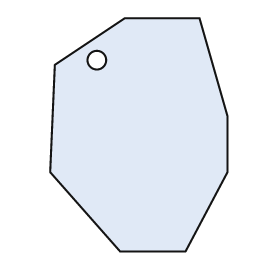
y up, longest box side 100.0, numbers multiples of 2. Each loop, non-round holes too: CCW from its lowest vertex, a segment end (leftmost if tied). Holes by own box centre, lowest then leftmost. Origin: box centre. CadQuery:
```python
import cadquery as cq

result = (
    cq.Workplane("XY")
    .moveTo(-8.0, -50.0)
    .lineTo(20.0, -50.0)
    .lineTo(38.0, -16.0)
    .lineTo(38.0, 8.0)
    .lineTo(26.0, 50.0)
    .lineTo(-6.0, 50.0)
    .lineTo(-36.0, 30.0)
    .lineTo(-38.0, -16.0)
    .close()
    .moveTo(-18.0, 32.0)
    .circle(4.0)
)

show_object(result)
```